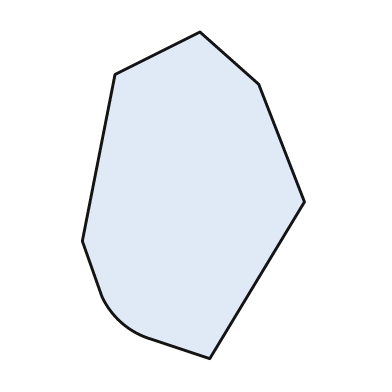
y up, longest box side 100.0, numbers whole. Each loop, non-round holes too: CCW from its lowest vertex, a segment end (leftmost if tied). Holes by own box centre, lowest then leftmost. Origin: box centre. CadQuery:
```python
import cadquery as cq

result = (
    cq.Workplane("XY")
    .moveTo(5.0, -50.0)
    .lineTo(34.0, -2.0)
    .lineTo(20.0, 34.0)
    .lineTo(2.0, 50.0)
    .lineTo(-24.0, 37.0)
    .lineTo(-34.0, -14.0)
    .lineTo(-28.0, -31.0)
    .threePointArc((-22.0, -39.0), (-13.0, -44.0))
    .close()
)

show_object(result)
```